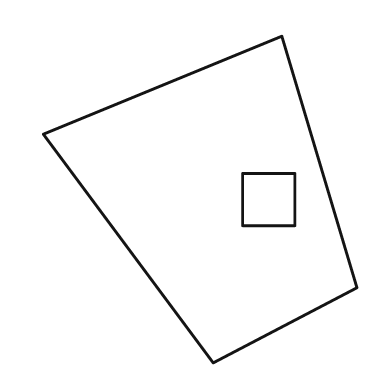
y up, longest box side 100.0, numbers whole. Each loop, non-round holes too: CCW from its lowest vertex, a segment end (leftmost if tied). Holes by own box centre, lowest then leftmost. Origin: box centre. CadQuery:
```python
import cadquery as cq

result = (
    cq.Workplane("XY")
    .moveTo(4.0, -50.0)
    .lineTo(48.0, -27.0)
    .lineTo(25.0, 50.0)
    .lineTo(-48.0, 20.0)
    .close()
    .moveTo(13.0, -8.0)
    .lineTo(29.0, -8.0)
    .lineTo(29.0, 8.0)
    .lineTo(13.0, 8.0)
    .close()
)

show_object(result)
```